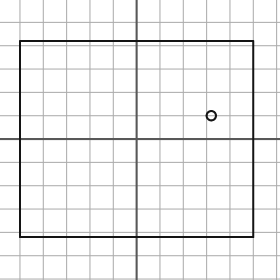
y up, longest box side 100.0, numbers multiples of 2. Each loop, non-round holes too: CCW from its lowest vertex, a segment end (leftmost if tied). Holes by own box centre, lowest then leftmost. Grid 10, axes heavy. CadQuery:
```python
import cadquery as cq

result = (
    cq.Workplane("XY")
    .moveTo(-50.0, -42.0)
    .lineTo(50.0, -42.0)
    .lineTo(50.0, 42.0)
    .lineTo(-50.0, 42.0)
    .close()
    .moveTo(32.0, 10.0)
    .circle(2.0)
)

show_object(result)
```